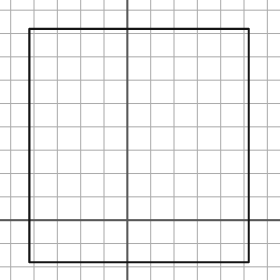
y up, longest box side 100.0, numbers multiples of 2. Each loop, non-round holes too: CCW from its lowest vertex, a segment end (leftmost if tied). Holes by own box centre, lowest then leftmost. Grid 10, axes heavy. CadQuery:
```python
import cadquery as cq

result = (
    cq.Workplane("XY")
    .moveTo(-42.0, -18.0)
    .lineTo(52.0, -18.0)
    .lineTo(52.0, 82.0)
    .lineTo(-42.0, 82.0)
    .close()
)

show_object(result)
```